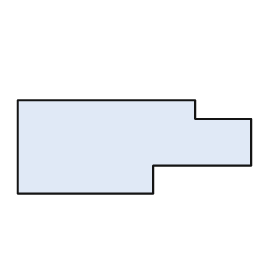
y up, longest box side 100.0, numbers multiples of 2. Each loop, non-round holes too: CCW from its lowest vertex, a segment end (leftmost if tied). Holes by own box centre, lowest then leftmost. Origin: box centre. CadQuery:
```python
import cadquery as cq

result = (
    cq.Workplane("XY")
    .moveTo(-50.0, -20.0)
    .lineTo(8.0, -20.0)
    .lineTo(8.0, -8.0)
    .lineTo(50.0, -8.0)
    .lineTo(50.0, 12.0)
    .lineTo(26.0, 12.0)
    .lineTo(26.0, 20.0)
    .lineTo(-50.0, 20.0)
    .close()
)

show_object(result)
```